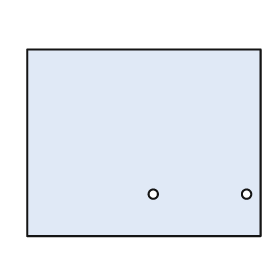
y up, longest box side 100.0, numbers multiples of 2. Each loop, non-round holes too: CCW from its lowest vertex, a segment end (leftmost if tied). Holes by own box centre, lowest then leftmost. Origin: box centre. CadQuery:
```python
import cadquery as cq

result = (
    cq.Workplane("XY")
    .moveTo(-50.0, -40.0)
    .lineTo(50.0, -40.0)
    .lineTo(50.0, 40.0)
    .lineTo(-50.0, 40.0)
    .close()
    .moveTo(4.0, -22.0)
    .circle(2.0)
    .moveTo(44.0, -22.0)
    .circle(2.0)
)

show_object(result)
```